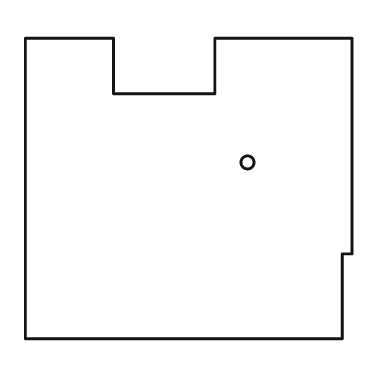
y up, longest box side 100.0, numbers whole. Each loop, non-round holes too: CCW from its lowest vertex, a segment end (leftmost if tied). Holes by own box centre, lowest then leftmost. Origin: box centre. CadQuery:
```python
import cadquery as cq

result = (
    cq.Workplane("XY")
    .moveTo(-50.0, -46.0)
    .lineTo(47.0, -46.0)
    .lineTo(47.0, -20.0)
    .lineTo(50.0, -20.0)
    .lineTo(50.0, 46.0)
    .lineTo(8.0, 46.0)
    .lineTo(8.0, 29.0)
    .lineTo(-23.0, 29.0)
    .lineTo(-23.0, 46.0)
    .lineTo(-50.0, 46.0)
    .close()
    .moveTo(18.0, 8.0)
    .circle(2.0)
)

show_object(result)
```